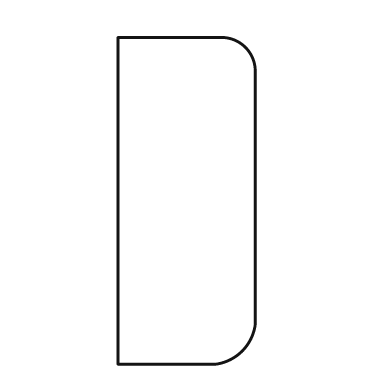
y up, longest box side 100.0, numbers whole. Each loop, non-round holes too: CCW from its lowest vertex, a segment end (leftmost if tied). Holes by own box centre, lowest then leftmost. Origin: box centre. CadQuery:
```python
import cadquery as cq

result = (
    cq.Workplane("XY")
    .moveTo(-21.0, -50.0)
    .lineTo(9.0, -50.0)
    .threePointArc((17.0, -46.0), (21.0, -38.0))
    .lineTo(21.0, 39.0)
    .threePointArc((18.0, 47.0), (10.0, 50.0))
    .lineTo(-21.0, 50.0)
    .close()
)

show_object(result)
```